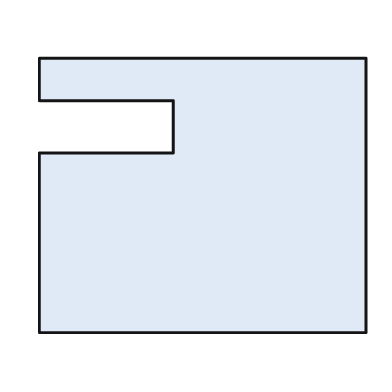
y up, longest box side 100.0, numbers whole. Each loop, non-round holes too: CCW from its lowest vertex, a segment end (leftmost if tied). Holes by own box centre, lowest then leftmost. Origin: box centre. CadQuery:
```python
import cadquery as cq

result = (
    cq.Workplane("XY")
    .moveTo(-50.0, -42.0)
    .lineTo(50.0, -42.0)
    .lineTo(50.0, 42.0)
    .lineTo(-50.0, 42.0)
    .lineTo(-50.0, 29.0)
    .lineTo(-9.0, 29.0)
    .lineTo(-9.0, 13.0)
    .lineTo(-50.0, 13.0)
    .close()
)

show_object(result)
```